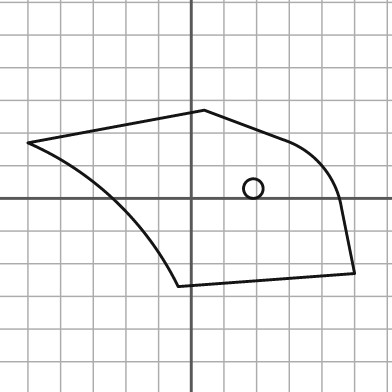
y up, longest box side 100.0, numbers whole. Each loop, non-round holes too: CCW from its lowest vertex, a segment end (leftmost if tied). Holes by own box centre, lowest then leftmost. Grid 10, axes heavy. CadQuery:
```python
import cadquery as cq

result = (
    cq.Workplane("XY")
    .moveTo(-4.0, -27.0)
    .lineTo(50.0, -23.0)
    .lineTo(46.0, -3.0)
    .threePointArc((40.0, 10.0), (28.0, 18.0))
    .lineTo(4.0, 27.0)
    .lineTo(-50.0, 17.0)
    .threePointArc((-23.0, -1.0), (-4.0, -27.0))
    .close()
    .moveTo(19.0, 3.0)
    .circle(3.0)
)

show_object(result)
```